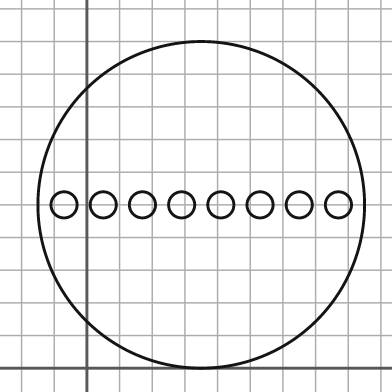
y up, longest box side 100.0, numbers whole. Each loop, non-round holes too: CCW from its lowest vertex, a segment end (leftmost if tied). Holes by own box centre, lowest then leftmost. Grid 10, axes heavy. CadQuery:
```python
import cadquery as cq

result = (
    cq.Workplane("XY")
    .moveTo(35.0, 50.0)
    .circle(50.0)
    .moveTo(-7.0, 50.0)
    .circle(4.0)
    .moveTo(5.0, 50.0)
    .circle(4.0)
    .moveTo(17.0, 50.0)
    .circle(4.0)
    .moveTo(29.0, 50.0)
    .circle(4.0)
    .moveTo(41.0, 50.0)
    .circle(4.0)
    .moveTo(53.0, 50.0)
    .circle(4.0)
    .moveTo(65.0, 50.0)
    .circle(4.0)
    .moveTo(77.0, 50.0)
    .circle(4.0)
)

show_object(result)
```